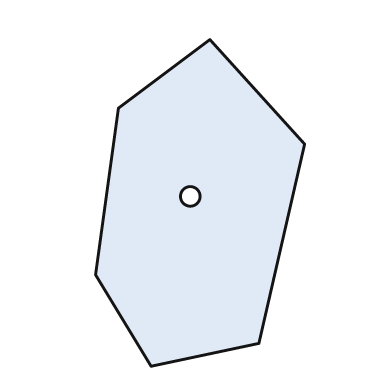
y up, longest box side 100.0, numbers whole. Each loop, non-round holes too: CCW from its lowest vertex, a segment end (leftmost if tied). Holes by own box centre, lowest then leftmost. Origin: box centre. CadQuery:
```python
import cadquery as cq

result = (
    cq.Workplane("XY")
    .moveTo(-15.0, -50.0)
    .lineTo(18.0, -43.0)
    .lineTo(32.0, 18.0)
    .lineTo(3.0, 50.0)
    .lineTo(-25.0, 29.0)
    .lineTo(-32.0, -22.0)
    .close()
    .moveTo(-3.0, 2.0)
    .circle(3.0)
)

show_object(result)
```